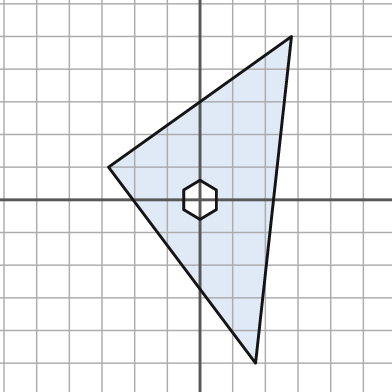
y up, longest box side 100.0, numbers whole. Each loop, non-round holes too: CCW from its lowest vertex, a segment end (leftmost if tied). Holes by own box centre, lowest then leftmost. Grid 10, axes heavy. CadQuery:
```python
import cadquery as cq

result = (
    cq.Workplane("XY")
    .moveTo(17.0, -50.0)
    .lineTo(28.0, 50.0)
    .lineTo(-28.0, 10.0)
    .close()
    .moveTo(0.0, -6.0)
    .lineTo(5.0, -3.0)
    .lineTo(5.0, 3.0)
    .lineTo(0.0, 6.0)
    .lineTo(-5.0, 3.0)
    .lineTo(-5.0, -3.0)
    .close()
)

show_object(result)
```